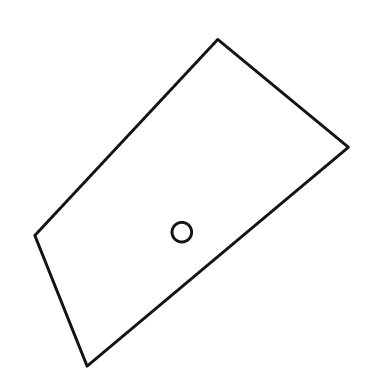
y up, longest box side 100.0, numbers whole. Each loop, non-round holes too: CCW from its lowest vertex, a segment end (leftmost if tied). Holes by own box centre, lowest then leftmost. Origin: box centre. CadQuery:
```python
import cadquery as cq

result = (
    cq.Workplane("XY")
    .moveTo(-32.0, -50.0)
    .lineTo(48.0, 17.0)
    .lineTo(8.0, 50.0)
    .lineTo(-48.0, -10.0)
    .close()
    .moveTo(-3.0, -9.0)
    .circle(3.0)
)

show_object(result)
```